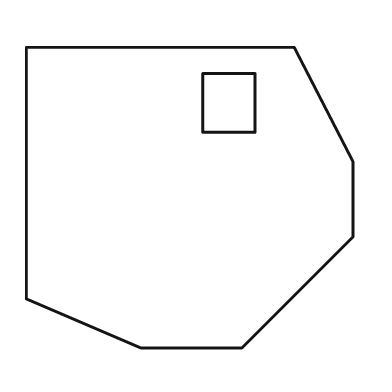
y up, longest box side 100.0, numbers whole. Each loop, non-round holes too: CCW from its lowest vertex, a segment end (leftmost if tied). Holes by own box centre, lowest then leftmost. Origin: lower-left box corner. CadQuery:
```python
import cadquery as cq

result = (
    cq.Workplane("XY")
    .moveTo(35.0, 0.0)
    .lineTo(66.0, 0.0)
    .lineTo(100.0, 34.0)
    .lineTo(100.0, 57.0)
    .lineTo(82.0, 92.0)
    .lineTo(0.0, 92.0)
    .lineTo(0.0, 15.0)
    .close()
    .moveTo(54.0, 66.0)
    .lineTo(70.0, 66.0)
    .lineTo(70.0, 84.0)
    .lineTo(54.0, 84.0)
    .close()
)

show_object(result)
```